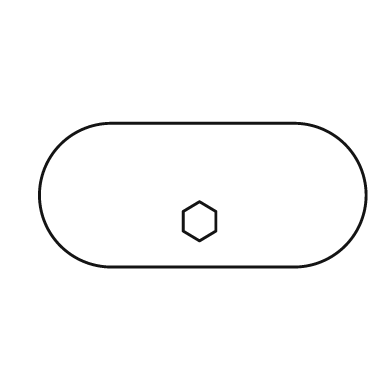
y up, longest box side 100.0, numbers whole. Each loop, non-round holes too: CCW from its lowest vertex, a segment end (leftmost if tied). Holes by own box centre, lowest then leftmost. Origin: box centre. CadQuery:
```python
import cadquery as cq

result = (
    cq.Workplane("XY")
    .moveTo(-28.0, -22.0)
    .lineTo(28.0, -22.0)
    .threePointArc((50.0, 0.0), (28.0, 22.0))
    .lineTo(-28.0, 22.0)
    .threePointArc((-50.0, 0.0), (-28.0, -22.0))
    .close()
    .moveTo(-1.0, -14.0)
    .lineTo(4.0, -11.0)
    .lineTo(4.0, -5.0)
    .lineTo(-1.0, -2.0)
    .lineTo(-6.0, -5.0)
    .lineTo(-6.0, -11.0)
    .close()
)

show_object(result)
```